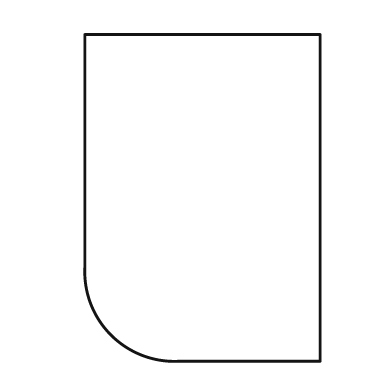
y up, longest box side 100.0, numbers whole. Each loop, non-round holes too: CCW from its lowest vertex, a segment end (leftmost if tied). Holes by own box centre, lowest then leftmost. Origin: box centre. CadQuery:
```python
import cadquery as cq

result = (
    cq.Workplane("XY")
    .moveTo(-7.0, -50.0)
    .lineTo(36.0, -50.0)
    .lineTo(36.0, 50.0)
    .lineTo(-36.0, 50.0)
    .lineTo(-36.0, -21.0)
    .threePointArc((-28.0, -42.0), (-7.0, -50.0))
    .close()
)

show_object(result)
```